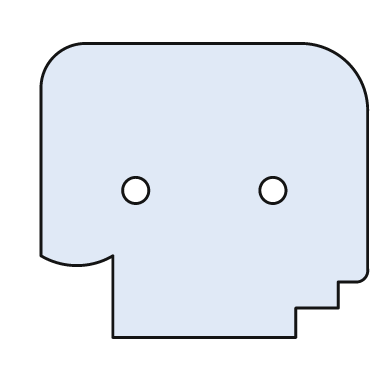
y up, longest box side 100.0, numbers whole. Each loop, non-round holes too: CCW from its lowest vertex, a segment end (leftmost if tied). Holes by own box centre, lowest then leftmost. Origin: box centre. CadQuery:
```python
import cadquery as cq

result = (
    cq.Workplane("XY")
    .moveTo(-28.0, -45.0)
    .lineTo(28.0, -45.0)
    .lineTo(28.0, -36.0)
    .lineTo(41.0, -36.0)
    .lineTo(41.0, -28.0)
    .lineTo(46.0, -28.0)
    .threePointArc((49.0, -27.0), (50.0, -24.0))
    .lineTo(50.0, 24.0)
    .threePointArc((44.0, 39.0), (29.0, 45.0))
    .lineTo(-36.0, 45.0)
    .threePointArc((-46.0, 41.0), (-50.0, 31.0))
    .lineTo(-50.0, -20.0)
    .threePointArc((-39.0, -23.0), (-28.0, -20.0))
    .close()
    .moveTo(-21.0, 0.0)
    .circle(4.0)
    .moveTo(21.0, 0.0)
    .circle(4.0)
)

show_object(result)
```